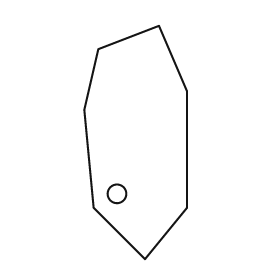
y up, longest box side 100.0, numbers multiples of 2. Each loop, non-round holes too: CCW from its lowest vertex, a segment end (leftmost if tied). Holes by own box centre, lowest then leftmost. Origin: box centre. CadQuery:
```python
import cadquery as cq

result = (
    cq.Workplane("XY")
    .moveTo(4.0, -50.0)
    .lineTo(22.0, -28.0)
    .lineTo(22.0, 22.0)
    .lineTo(10.0, 50.0)
    .lineTo(-16.0, 40.0)
    .lineTo(-22.0, 14.0)
    .lineTo(-18.0, -28.0)
    .close()
    .moveTo(-8.0, -22.0)
    .circle(4.0)
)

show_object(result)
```